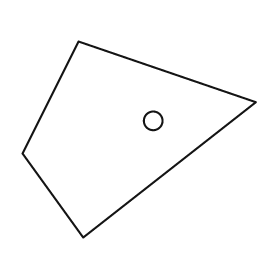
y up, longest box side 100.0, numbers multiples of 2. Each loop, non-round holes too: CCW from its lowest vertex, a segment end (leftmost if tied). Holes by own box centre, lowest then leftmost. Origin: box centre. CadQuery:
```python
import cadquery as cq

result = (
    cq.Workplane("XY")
    .moveTo(-24.0, -42.0)
    .lineTo(50.0, 16.0)
    .lineTo(-26.0, 42.0)
    .lineTo(-50.0, -6.0)
    .close()
    .moveTo(6.0, 8.0)
    .circle(4.0)
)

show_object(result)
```